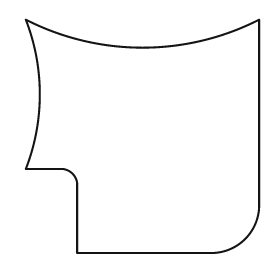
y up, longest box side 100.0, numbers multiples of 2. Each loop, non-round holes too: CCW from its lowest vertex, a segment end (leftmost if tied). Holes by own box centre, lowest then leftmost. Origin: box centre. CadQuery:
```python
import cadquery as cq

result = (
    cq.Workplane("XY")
    .moveTo(-28.0, -50.0)
    .lineTo(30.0, -50.0)
    .threePointArc((44.0, -44.0), (50.0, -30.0))
    .lineTo(50.0, 50.0)
    .threePointArc((0.0, 38.0), (-50.0, 50.0))
    .threePointArc((-44.0, 18.0), (-50.0, -14.0))
    .lineTo(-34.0, -14.0)
    .threePointArc((-30.0, -16.0), (-28.0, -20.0))
    .close()
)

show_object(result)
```